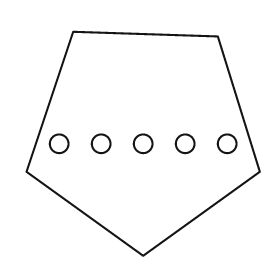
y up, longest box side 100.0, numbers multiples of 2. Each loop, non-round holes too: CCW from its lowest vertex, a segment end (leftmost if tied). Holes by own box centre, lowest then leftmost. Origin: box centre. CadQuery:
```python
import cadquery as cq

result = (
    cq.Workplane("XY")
    .moveTo(0.0, -48.0)
    .lineTo(50.0, -12.0)
    .lineTo(32.0, 46.0)
    .lineTo(-30.0, 48.0)
    .lineTo(-50.0, -12.0)
    .close()
    .moveTo(-36.0, 0.0)
    .circle(4.0)
    .moveTo(-18.0, 0.0)
    .circle(4.0)
    .moveTo(0.0, 0.0)
    .circle(4.0)
    .moveTo(18.0, 0.0)
    .circle(4.0)
    .moveTo(36.0, 0.0)
    .circle(4.0)
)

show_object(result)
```